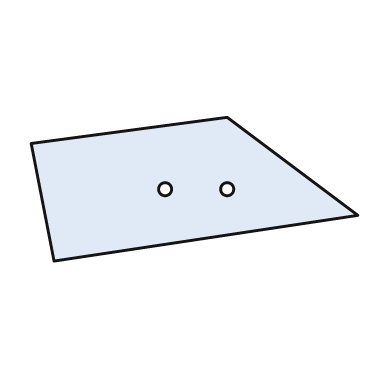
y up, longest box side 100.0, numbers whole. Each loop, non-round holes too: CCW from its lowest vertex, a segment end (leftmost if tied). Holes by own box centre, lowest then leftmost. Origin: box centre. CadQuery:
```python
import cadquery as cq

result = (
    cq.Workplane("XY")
    .moveTo(-43.0, -22.0)
    .lineTo(50.0, -8.0)
    .lineTo(10.0, 22.0)
    .lineTo(-50.0, 14.0)
    .close()
    .moveTo(-9.0, 0.0)
    .circle(2.0)
    .moveTo(10.0, 0.0)
    .circle(2.0)
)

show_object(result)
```